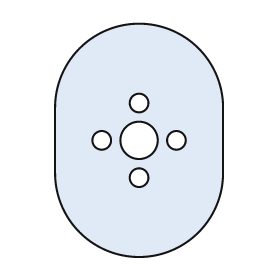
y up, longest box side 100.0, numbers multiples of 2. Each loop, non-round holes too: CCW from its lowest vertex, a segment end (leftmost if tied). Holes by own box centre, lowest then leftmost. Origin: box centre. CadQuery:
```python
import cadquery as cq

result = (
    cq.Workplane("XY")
    .moveTo(-36.0, -14.0)
    .threePointArc((0.0, -50.0), (36.0, -14.0))
    .lineTo(36.0, 14.0)
    .threePointArc((0.0, 50.0), (-36.0, 14.0))
    .close()
    .moveTo(0.0, -16.0)
    .circle(4.0)
    .moveTo(-16.0, 0.0)
    .circle(4.0)
    .moveTo(0.0, 0.0)
    .circle(8.0)
    .moveTo(16.0, 0.0)
    .circle(4.0)
    .moveTo(0.0, 16.0)
    .circle(4.0)
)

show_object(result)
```